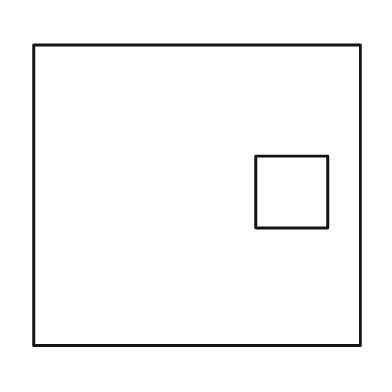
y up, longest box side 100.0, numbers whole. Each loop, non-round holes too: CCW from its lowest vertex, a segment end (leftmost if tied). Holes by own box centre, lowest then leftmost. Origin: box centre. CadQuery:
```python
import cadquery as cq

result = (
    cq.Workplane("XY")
    .moveTo(-50.0, -46.0)
    .lineTo(50.0, -46.0)
    .lineTo(50.0, 46.0)
    .lineTo(-50.0, 46.0)
    .close()
    .moveTo(18.0, -10.0)
    .lineTo(40.0, -10.0)
    .lineTo(40.0, 12.0)
    .lineTo(18.0, 12.0)
    .close()
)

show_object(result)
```